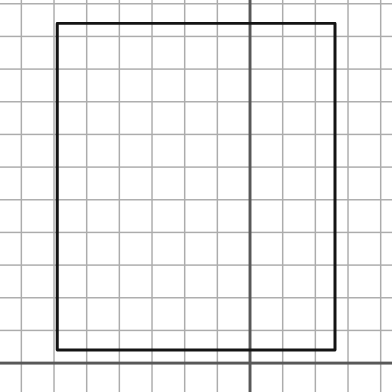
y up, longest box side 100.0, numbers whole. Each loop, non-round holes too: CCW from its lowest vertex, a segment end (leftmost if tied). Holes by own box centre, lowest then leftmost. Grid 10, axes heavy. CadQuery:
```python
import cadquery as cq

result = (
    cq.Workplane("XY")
    .moveTo(-59.0, 4.0)
    .lineTo(26.0, 4.0)
    .lineTo(26.0, 104.0)
    .lineTo(-59.0, 104.0)
    .close()
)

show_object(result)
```